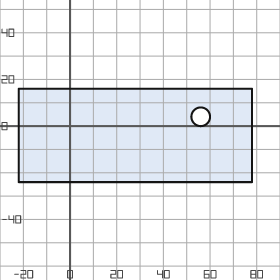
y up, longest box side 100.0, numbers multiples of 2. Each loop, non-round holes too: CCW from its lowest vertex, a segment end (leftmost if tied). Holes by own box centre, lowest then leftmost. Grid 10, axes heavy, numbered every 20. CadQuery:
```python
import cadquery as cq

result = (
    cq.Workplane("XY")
    .moveTo(-22.0, -24.0)
    .lineTo(78.0, -24.0)
    .lineTo(78.0, 16.0)
    .lineTo(-22.0, 16.0)
    .close()
    .moveTo(56.0, 4.0)
    .circle(4.0)
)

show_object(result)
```